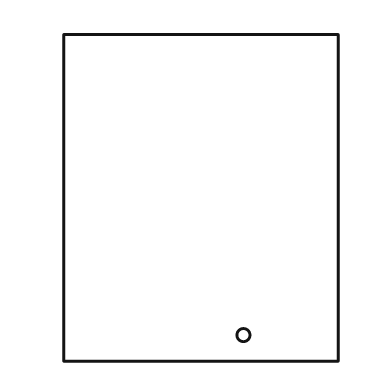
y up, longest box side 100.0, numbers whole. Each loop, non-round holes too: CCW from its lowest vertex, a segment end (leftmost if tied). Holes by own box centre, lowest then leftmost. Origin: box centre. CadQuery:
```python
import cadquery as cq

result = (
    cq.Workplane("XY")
    .moveTo(-42.0, -50.0)
    .lineTo(42.0, -50.0)
    .lineTo(42.0, 50.0)
    .lineTo(-42.0, 50.0)
    .close()
    .moveTo(13.0, -42.0)
    .circle(2.0)
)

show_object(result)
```